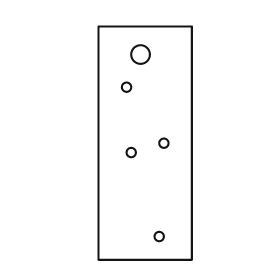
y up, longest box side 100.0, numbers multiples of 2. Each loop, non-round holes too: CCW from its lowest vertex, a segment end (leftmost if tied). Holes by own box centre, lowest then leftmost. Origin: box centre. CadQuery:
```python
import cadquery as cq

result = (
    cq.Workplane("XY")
    .moveTo(-20.0, -50.0)
    .lineTo(20.0, -50.0)
    .lineTo(20.0, 50.0)
    .lineTo(-20.0, 50.0)
    .close()
    .moveTo(6.0, -40.0)
    .circle(2.0)
    .moveTo(-6.0, -4.0)
    .circle(2.0)
    .moveTo(8.0, 0.0)
    .circle(2.0)
    .moveTo(-8.0, 24.0)
    .circle(2.0)
    .moveTo(-2.0, 38.0)
    .circle(4.0)
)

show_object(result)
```